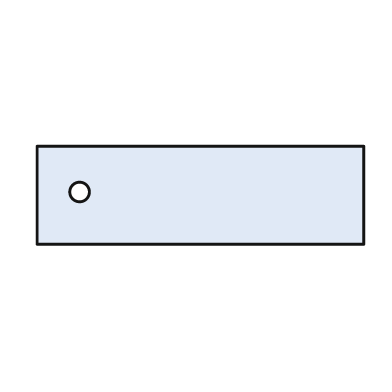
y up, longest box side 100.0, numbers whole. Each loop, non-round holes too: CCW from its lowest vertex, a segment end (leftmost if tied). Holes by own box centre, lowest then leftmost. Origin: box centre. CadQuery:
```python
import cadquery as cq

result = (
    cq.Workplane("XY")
    .moveTo(-50.0, -15.0)
    .lineTo(50.0, -15.0)
    .lineTo(50.0, 15.0)
    .lineTo(-50.0, 15.0)
    .close()
    .moveTo(-37.0, 1.0)
    .circle(3.0)
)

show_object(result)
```